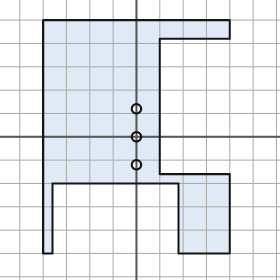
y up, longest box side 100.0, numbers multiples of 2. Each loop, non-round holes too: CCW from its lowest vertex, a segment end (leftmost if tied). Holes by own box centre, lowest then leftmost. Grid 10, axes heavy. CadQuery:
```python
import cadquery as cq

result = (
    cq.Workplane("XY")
    .moveTo(-40.0, -50.0)
    .lineTo(-36.0, -50.0)
    .lineTo(-36.0, -20.0)
    .lineTo(18.0, -20.0)
    .lineTo(18.0, -50.0)
    .lineTo(40.0, -50.0)
    .lineTo(40.0, -16.0)
    .lineTo(10.0, -16.0)
    .lineTo(10.0, 42.0)
    .lineTo(40.0, 42.0)
    .lineTo(40.0, 50.0)
    .lineTo(-40.0, 50.0)
    .close()
    .moveTo(0.0, -12.0)
    .circle(2.0)
    .moveTo(0.0, 0.0)
    .circle(2.0)
    .moveTo(0.0, 12.0)
    .circle(2.0)
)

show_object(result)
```